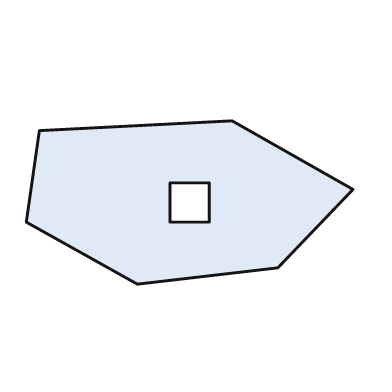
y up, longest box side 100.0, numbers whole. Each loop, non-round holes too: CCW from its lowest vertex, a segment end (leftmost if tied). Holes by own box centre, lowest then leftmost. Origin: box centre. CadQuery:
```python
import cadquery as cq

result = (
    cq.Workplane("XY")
    .moveTo(-16.0, -25.0)
    .lineTo(27.0, -20.0)
    .lineTo(50.0, 4.0)
    .lineTo(13.0, 25.0)
    .lineTo(-46.0, 22.0)
    .lineTo(-50.0, -6.0)
    .close()
    .moveTo(-6.0, -6.0)
    .lineTo(6.0, -6.0)
    .lineTo(6.0, 6.0)
    .lineTo(-6.0, 6.0)
    .close()
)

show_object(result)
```